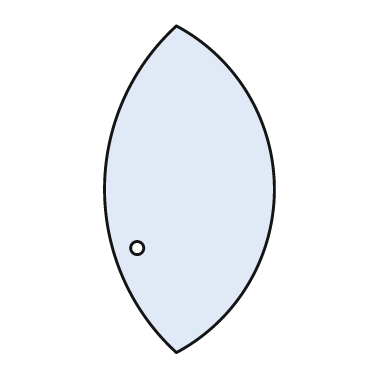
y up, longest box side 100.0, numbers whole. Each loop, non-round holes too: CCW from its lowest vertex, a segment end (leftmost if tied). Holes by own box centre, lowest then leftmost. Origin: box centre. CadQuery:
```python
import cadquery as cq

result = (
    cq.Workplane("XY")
    .moveTo(-4.0, -50.0)
    .threePointArc((26.0, 0.0), (-4.0, 50.0))
    .threePointArc((-26.0, 0.0), (-4.0, -50.0))
    .close()
    .moveTo(-16.0, -18.0)
    .circle(2.0)
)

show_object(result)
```